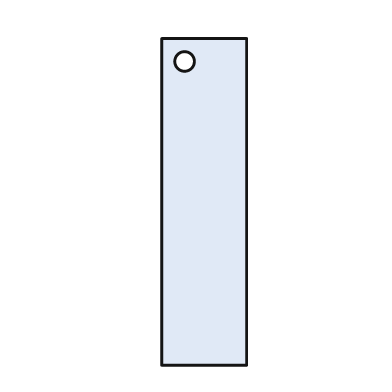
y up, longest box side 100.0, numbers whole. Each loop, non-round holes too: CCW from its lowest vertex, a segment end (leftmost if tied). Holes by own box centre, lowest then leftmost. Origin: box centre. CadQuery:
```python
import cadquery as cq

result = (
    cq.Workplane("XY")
    .moveTo(-13.0, -50.0)
    .lineTo(13.0, -50.0)
    .lineTo(13.0, 50.0)
    .lineTo(-13.0, 50.0)
    .close()
    .moveTo(-6.0, 43.0)
    .circle(3.0)
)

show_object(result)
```